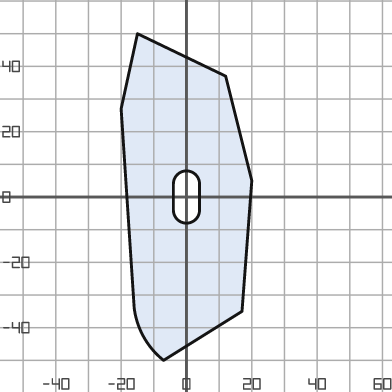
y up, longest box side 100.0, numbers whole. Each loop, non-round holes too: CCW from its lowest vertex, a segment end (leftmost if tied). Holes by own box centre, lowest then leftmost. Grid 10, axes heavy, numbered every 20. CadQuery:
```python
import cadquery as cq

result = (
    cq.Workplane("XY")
    .moveTo(-7.0, -50.0)
    .lineTo(17.0, -35.0)
    .lineTo(20.0, 5.0)
    .lineTo(12.0, 37.0)
    .lineTo(-15.0, 50.0)
    .lineTo(-20.0, 27.0)
    .lineTo(-16.0, -34.0)
    .threePointArc((-13.0, -43.0), (-7.0, -50.0))
    .close()
    .moveTo(-4.0, -4.0)
    .threePointArc((0.0, -8.0), (4.0, -4.0))
    .lineTo(4.0, 4.0)
    .threePointArc((0.0, 8.0), (-4.0, 4.0))
    .close()
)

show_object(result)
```